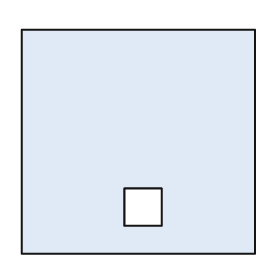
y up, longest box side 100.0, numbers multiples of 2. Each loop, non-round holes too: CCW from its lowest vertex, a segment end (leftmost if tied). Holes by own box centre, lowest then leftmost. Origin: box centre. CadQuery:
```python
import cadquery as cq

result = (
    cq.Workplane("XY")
    .moveTo(-50.0, -48.0)
    .lineTo(50.0, -48.0)
    .lineTo(50.0, 48.0)
    .lineTo(-50.0, 48.0)
    .close()
    .moveTo(-6.0, -36.0)
    .lineTo(10.0, -36.0)
    .lineTo(10.0, -20.0)
    .lineTo(-6.0, -20.0)
    .close()
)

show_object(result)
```